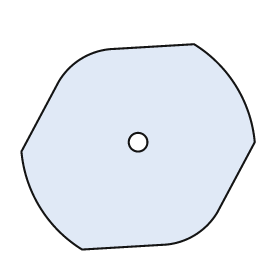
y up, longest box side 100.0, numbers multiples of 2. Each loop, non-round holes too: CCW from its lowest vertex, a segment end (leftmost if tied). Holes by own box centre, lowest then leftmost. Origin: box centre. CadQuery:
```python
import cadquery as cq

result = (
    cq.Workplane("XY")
    .moveTo(-24.0, -44.0)
    .lineTo(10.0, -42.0)
    .threePointArc((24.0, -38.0), (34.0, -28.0))
    .lineTo(50.0, 2.0)
    .threePointArc((42.0, 26.0), (24.0, 44.0))
    .lineTo(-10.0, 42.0)
    .threePointArc((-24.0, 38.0), (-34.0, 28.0))
    .lineTo(-50.0, -2.0)
    .threePointArc((-42.0, -26.0), (-24.0, -44.0))
    .close()
    .moveTo(0.0, 2.0)
    .circle(4.0)
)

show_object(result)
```